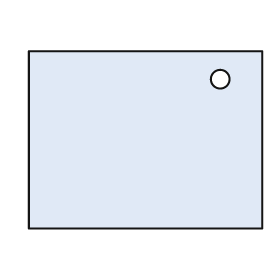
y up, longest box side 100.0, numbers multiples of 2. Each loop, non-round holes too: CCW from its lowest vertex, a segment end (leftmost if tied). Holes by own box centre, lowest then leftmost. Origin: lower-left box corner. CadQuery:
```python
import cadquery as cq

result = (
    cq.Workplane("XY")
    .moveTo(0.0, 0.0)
    .lineTo(100.0, 0.0)
    .lineTo(100.0, 76.0)
    .lineTo(0.0, 76.0)
    .close()
    .moveTo(82.0, 64.0)
    .circle(4.0)
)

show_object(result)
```